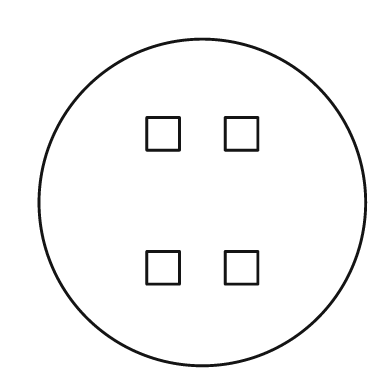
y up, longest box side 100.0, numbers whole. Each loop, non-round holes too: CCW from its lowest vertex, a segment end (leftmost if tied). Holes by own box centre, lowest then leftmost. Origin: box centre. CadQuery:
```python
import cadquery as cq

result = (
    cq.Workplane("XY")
    .moveTo(0.0, 0.0)
    .circle(50.0)
    .moveTo(-17.0, -25.0)
    .lineTo(-7.0, -25.0)
    .lineTo(-7.0, -15.0)
    .lineTo(-17.0, -15.0)
    .close()
    .moveTo(7.0, -25.0)
    .lineTo(17.0, -25.0)
    .lineTo(17.0, -15.0)
    .lineTo(7.0, -15.0)
    .close()
    .moveTo(-17.0, 16.0)
    .lineTo(-7.0, 16.0)
    .lineTo(-7.0, 26.0)
    .lineTo(-17.0, 26.0)
    .close()
    .moveTo(7.0, 16.0)
    .lineTo(17.0, 16.0)
    .lineTo(17.0, 26.0)
    .lineTo(7.0, 26.0)
    .close()
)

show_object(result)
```